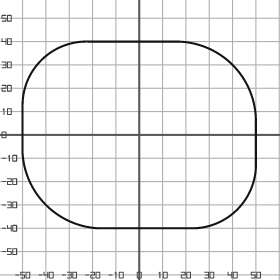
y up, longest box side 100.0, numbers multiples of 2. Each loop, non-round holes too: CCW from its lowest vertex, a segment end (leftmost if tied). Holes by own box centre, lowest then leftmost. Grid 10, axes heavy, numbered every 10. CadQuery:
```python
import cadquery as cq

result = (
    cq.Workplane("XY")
    .moveTo(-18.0, -40.0)
    .lineTo(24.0, -40.0)
    .threePointArc((42.0, -32.0), (50.0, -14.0))
    .lineTo(50.0, 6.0)
    .threePointArc((40.0, 30.0), (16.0, 40.0))
    .lineTo(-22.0, 40.0)
    .threePointArc((-42.0, 32.0), (-50.0, 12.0))
    .lineTo(-50.0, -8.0)
    .threePointArc((-40.0, -30.0), (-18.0, -40.0))
    .close()
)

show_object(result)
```